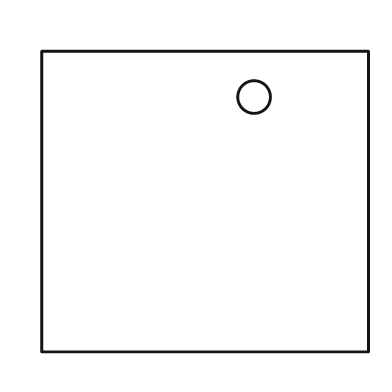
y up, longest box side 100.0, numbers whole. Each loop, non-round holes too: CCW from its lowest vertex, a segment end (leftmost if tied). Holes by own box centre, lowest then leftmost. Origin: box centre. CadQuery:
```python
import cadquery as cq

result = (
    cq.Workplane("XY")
    .moveTo(-50.0, -46.0)
    .lineTo(50.0, -46.0)
    .lineTo(50.0, 46.0)
    .lineTo(-50.0, 46.0)
    .close()
    .moveTo(15.0, 32.0)
    .circle(5.0)
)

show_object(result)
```